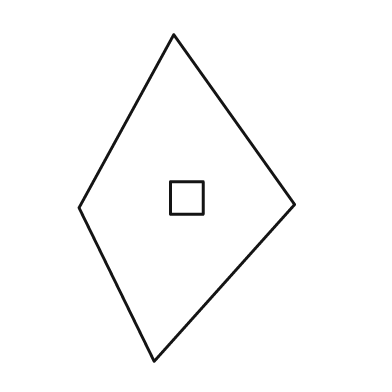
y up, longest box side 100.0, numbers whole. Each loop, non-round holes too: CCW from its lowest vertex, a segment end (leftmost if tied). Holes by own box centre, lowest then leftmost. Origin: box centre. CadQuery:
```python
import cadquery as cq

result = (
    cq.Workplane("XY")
    .moveTo(-10.0, -50.0)
    .lineTo(33.0, -2.0)
    .lineTo(-4.0, 50.0)
    .lineTo(-33.0, -3.0)
    .close()
    .moveTo(-5.0, -5.0)
    .lineTo(5.0, -5.0)
    .lineTo(5.0, 5.0)
    .lineTo(-5.0, 5.0)
    .close()
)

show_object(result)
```